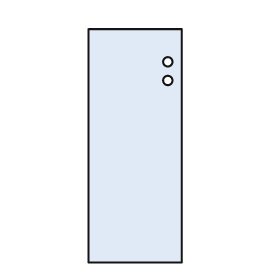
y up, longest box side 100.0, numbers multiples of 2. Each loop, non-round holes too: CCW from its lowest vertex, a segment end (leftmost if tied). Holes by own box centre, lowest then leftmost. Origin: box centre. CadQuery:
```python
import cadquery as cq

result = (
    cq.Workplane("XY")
    .moveTo(-20.0, -50.0)
    .lineTo(20.0, -50.0)
    .lineTo(20.0, 50.0)
    .lineTo(-20.0, 50.0)
    .close()
    .moveTo(14.0, 28.0)
    .circle(2.0)
    .moveTo(14.0, 36.0)
    .circle(2.0)
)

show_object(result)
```